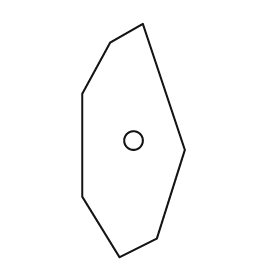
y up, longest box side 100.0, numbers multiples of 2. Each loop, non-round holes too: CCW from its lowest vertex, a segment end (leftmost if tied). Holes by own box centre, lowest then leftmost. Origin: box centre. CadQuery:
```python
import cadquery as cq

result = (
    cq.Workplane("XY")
    .moveTo(-6.0, -50.0)
    .lineTo(10.0, -42.0)
    .lineTo(22.0, -4.0)
    .lineTo(4.0, 50.0)
    .lineTo(-10.0, 42.0)
    .lineTo(-22.0, 20.0)
    .lineTo(-22.0, -24.0)
    .close()
    .moveTo(0.0, 0.0)
    .circle(4.0)
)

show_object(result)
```